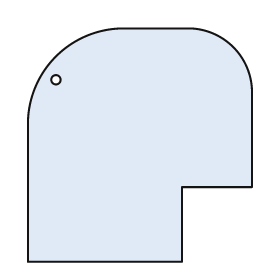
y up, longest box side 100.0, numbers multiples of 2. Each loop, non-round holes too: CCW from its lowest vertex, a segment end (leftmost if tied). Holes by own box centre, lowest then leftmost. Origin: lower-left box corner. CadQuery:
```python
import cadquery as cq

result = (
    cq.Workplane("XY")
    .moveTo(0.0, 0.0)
    .lineTo(66.0, 0.0)
    .lineTo(66.0, 32.0)
    .lineTo(96.0, 32.0)
    .lineTo(96.0, 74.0)
    .threePointArc((88.0, 92.0), (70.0, 100.0))
    .lineTo(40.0, 100.0)
    .threePointArc((12.0, 88.0), (0.0, 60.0))
    .close()
    .moveTo(12.0, 78.0)
    .circle(2.0)
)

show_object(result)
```